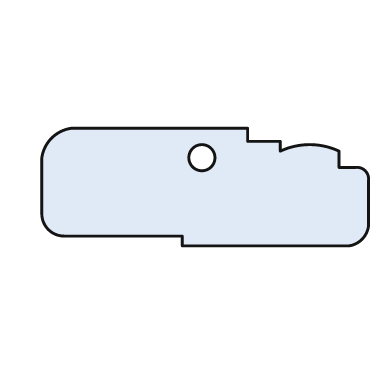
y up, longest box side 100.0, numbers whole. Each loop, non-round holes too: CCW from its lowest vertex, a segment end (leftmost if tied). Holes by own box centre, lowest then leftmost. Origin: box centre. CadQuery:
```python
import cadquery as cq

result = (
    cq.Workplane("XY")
    .moveTo(-7.0, -18.0)
    .lineTo(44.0, -18.0)
    .threePointArc((48.0, -16.0), (50.0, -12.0))
    .lineTo(50.0, 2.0)
    .threePointArc((49.0, 5.0), (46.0, 6.0))
    .lineTo(41.0, 6.0)
    .lineTo(41.0, 11.0)
    .threePointArc((32.0, 13.0), (23.0, 11.0))
    .lineTo(23.0, 14.0)
    .lineTo(13.0, 14.0)
    .lineTo(13.0, 18.0)
    .lineTo(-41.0, 18.0)
    .threePointArc((-47.0, 15.0), (-50.0, 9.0))
    .lineTo(-50.0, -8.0)
    .threePointArc((-48.0, -13.0), (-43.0, -15.0))
    .lineTo(-7.0, -15.0)
    .close()
    .moveTo(-1.0, 9.0)
    .circle(4.0)
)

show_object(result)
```